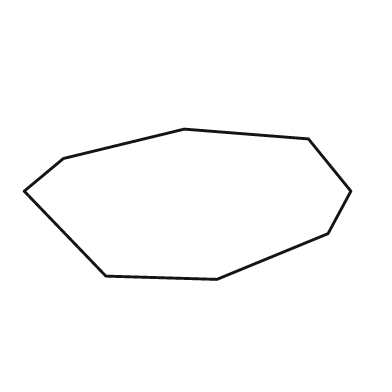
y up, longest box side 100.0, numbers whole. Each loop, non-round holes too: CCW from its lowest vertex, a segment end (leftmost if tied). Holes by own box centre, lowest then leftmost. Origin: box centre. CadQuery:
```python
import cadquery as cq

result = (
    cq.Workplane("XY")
    .moveTo(9.0, -23.0)
    .lineTo(43.0, -9.0)
    .lineTo(50.0, 4.0)
    .lineTo(37.0, 20.0)
    .lineTo(-1.0, 23.0)
    .lineTo(-38.0, 14.0)
    .lineTo(-50.0, 4.0)
    .lineTo(-25.0, -22.0)
    .close()
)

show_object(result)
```